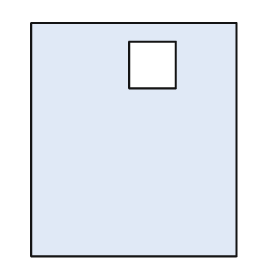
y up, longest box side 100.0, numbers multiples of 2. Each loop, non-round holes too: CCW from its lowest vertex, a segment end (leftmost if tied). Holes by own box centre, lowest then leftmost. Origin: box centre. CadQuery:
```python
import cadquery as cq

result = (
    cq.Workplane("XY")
    .moveTo(-44.0, -50.0)
    .lineTo(44.0, -50.0)
    .lineTo(44.0, 50.0)
    .lineTo(-44.0, 50.0)
    .close()
    .moveTo(-2.0, 22.0)
    .lineTo(18.0, 22.0)
    .lineTo(18.0, 42.0)
    .lineTo(-2.0, 42.0)
    .close()
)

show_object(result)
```